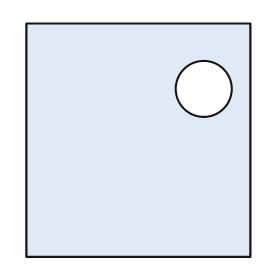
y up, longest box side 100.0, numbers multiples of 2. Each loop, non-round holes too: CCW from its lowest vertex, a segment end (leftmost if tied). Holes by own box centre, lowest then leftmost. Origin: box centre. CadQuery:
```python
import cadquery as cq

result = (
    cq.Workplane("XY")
    .moveTo(-48.0, -50.0)
    .lineTo(48.0, -50.0)
    .lineTo(48.0, 50.0)
    .lineTo(-48.0, 50.0)
    .close()
    .moveTo(28.0, 22.0)
    .circle(12.0)
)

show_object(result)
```